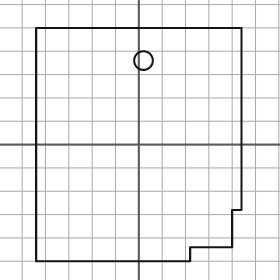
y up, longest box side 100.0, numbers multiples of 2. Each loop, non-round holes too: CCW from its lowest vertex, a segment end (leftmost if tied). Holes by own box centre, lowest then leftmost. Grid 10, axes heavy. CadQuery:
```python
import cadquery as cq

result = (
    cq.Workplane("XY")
    .moveTo(-44.0, -50.0)
    .lineTo(22.0, -50.0)
    .lineTo(22.0, -44.0)
    .lineTo(40.0, -44.0)
    .lineTo(40.0, -28.0)
    .lineTo(44.0, -28.0)
    .lineTo(44.0, 50.0)
    .lineTo(-44.0, 50.0)
    .close()
    .moveTo(2.0, 36.0)
    .circle(4.0)
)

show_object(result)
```